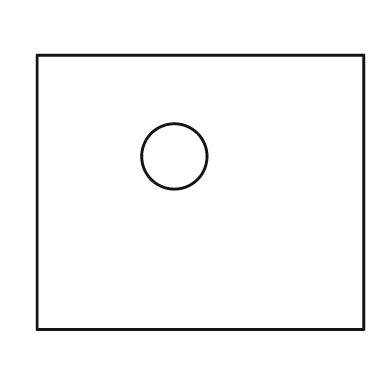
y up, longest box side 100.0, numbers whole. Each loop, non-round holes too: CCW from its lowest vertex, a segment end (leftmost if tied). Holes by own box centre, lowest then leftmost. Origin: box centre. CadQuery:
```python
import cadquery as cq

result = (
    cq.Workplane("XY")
    .moveTo(-50.0, -42.0)
    .lineTo(50.0, -42.0)
    .lineTo(50.0, 42.0)
    .lineTo(-50.0, 42.0)
    .close()
    .moveTo(-8.0, 11.0)
    .circle(10.0)
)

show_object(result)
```